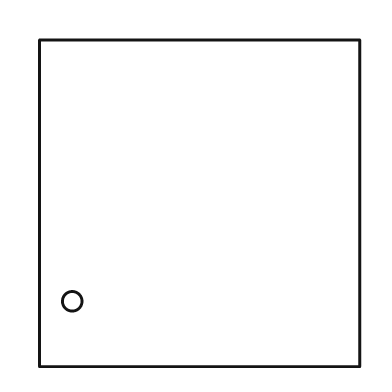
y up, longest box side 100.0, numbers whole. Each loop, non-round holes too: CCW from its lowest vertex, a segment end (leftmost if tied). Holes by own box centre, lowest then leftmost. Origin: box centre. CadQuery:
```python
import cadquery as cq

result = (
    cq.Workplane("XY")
    .moveTo(-49.0, -50.0)
    .lineTo(49.0, -50.0)
    .lineTo(49.0, 50.0)
    .lineTo(-49.0, 50.0)
    .close()
    .moveTo(-39.0, -30.0)
    .circle(3.0)
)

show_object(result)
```